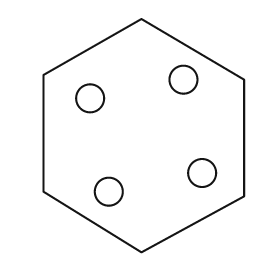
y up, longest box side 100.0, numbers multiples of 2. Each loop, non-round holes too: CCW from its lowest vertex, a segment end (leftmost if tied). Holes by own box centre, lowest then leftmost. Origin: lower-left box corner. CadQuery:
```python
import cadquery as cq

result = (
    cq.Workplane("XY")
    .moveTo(42.0, 0.0)
    .lineTo(86.0, 24.0)
    .lineTo(86.0, 74.0)
    .lineTo(42.0, 100.0)
    .lineTo(0.0, 76.0)
    .lineTo(0.0, 26.0)
    .close()
    .moveTo(28.0, 26.0)
    .circle(6.0)
    .moveTo(68.0, 34.0)
    .circle(6.0)
    .moveTo(20.0, 66.0)
    .circle(6.0)
    .moveTo(60.0, 74.0)
    .circle(6.0)
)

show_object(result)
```